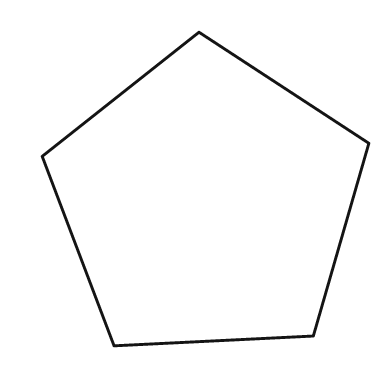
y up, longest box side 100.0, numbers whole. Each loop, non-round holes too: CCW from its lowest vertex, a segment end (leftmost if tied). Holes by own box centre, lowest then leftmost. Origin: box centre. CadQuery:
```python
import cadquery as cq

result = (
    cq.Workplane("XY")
    .moveTo(-28.0, -48.0)
    .lineTo(33.0, -45.0)
    .lineTo(50.0, 14.0)
    .lineTo(-2.0, 48.0)
    .lineTo(-50.0, 10.0)
    .close()
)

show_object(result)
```